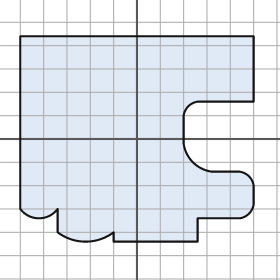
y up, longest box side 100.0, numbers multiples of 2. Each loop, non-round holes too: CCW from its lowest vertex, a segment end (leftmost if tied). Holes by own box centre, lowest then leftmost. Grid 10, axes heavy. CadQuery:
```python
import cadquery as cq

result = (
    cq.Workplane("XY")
    .moveTo(-10.0, -44.0)
    .lineTo(26.0, -44.0)
    .lineTo(26.0, -34.0)
    .lineTo(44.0, -34.0)
    .threePointArc((48.0, -32.0), (50.0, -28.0))
    .lineTo(50.0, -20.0)
    .threePointArc((48.0, -16.0), (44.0, -14.0))
    .lineTo(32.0, -14.0)
    .threePointArc((24.0, -10.0), (20.0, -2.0))
    .lineTo(20.0, 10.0)
    .threePointArc((22.0, 14.0), (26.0, 16.0))
    .lineTo(50.0, 16.0)
    .lineTo(50.0, 44.0)
    .lineTo(-50.0, 44.0)
    .lineTo(-50.0, -30.0)
    .threePointArc((-42.0, -34.0), (-34.0, -30.0))
    .lineTo(-34.0, -40.0)
    .threePointArc((-22.0, -44.0), (-10.0, -40.0))
    .close()
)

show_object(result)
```